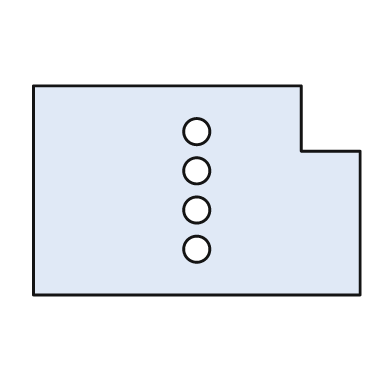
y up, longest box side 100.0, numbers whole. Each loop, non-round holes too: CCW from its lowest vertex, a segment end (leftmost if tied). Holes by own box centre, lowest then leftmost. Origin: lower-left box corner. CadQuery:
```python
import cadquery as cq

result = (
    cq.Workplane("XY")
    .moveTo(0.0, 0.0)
    .lineTo(100.0, 0.0)
    .lineTo(100.0, 44.0)
    .lineTo(82.0, 44.0)
    .lineTo(82.0, 64.0)
    .lineTo(0.0, 64.0)
    .close()
    .moveTo(50.0, 14.0)
    .circle(4.0)
    .moveTo(50.0, 26.0)
    .circle(4.0)
    .moveTo(50.0, 38.0)
    .circle(4.0)
    .moveTo(50.0, 50.0)
    .circle(4.0)
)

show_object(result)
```